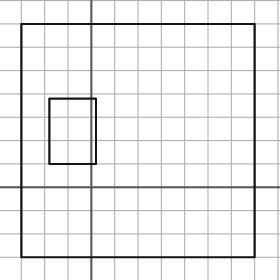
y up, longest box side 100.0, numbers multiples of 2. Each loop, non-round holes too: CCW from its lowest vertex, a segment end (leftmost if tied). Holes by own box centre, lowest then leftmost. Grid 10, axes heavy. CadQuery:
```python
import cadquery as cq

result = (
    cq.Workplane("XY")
    .moveTo(-30.0, -30.0)
    .lineTo(70.0, -30.0)
    .lineTo(70.0, 70.0)
    .lineTo(-30.0, 70.0)
    .close()
    .moveTo(-18.0, 10.0)
    .lineTo(2.0, 10.0)
    .lineTo(2.0, 38.0)
    .lineTo(-18.0, 38.0)
    .close()
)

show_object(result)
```